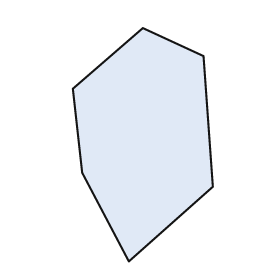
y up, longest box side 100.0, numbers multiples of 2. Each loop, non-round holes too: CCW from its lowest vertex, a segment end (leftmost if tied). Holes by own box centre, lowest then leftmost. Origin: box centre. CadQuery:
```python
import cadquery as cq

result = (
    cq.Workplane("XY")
    .moveTo(-6.0, -50.0)
    .lineTo(30.0, -18.0)
    .lineTo(26.0, 38.0)
    .lineTo(0.0, 50.0)
    .lineTo(-30.0, 24.0)
    .lineTo(-26.0, -12.0)
    .close()
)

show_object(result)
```